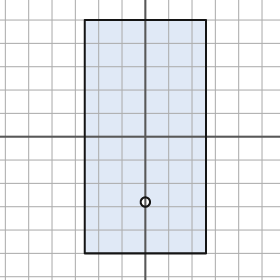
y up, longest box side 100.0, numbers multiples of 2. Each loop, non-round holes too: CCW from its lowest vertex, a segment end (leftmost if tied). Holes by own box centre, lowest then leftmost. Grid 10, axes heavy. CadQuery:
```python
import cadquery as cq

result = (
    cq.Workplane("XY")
    .moveTo(-26.0, -50.0)
    .lineTo(26.0, -50.0)
    .lineTo(26.0, 50.0)
    .lineTo(-26.0, 50.0)
    .close()
    .moveTo(0.0, -28.0)
    .circle(2.0)
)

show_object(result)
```